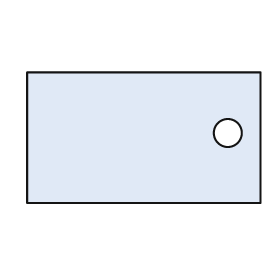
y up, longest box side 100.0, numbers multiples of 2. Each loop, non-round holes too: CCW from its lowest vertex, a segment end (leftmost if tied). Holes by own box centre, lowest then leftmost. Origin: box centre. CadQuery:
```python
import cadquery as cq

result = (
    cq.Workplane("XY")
    .moveTo(-50.0, -28.0)
    .lineTo(50.0, -28.0)
    .lineTo(50.0, 28.0)
    .lineTo(-50.0, 28.0)
    .close()
    .moveTo(36.0, 2.0)
    .circle(6.0)
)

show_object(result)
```